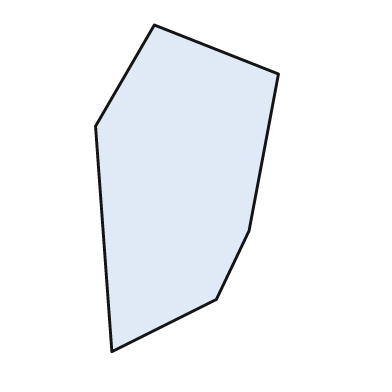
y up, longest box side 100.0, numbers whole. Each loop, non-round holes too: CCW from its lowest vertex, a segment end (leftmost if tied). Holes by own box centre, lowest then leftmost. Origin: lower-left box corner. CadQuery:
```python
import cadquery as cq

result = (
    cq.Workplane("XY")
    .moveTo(5.0, 0.0)
    .lineTo(37.0, 16.0)
    .lineTo(47.0, 37.0)
    .lineTo(56.0, 85.0)
    .lineTo(18.0, 100.0)
    .lineTo(0.0, 69.0)
    .close()
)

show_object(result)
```